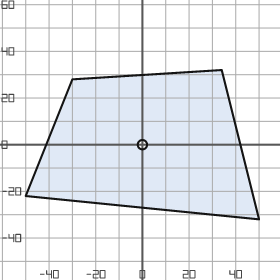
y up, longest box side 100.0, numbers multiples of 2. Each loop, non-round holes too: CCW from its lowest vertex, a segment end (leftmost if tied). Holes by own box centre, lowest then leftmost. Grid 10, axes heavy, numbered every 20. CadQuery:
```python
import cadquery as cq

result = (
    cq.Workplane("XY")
    .moveTo(50.0, -32.0)
    .lineTo(34.0, 32.0)
    .lineTo(-30.0, 28.0)
    .lineTo(-50.0, -22.0)
    .close()
    .moveTo(0.0, 0.0)
    .circle(2.0)
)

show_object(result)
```